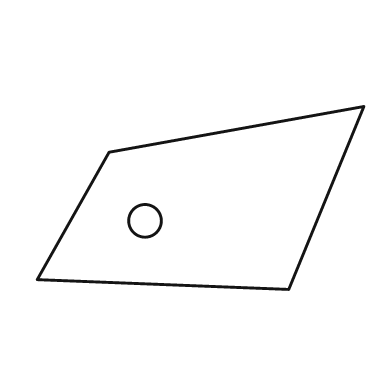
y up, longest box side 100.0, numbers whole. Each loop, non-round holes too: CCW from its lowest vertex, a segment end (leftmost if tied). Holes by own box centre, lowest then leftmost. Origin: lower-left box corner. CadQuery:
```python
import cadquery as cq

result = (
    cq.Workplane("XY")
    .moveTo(77.0, 0.0)
    .lineTo(100.0, 56.0)
    .lineTo(22.0, 42.0)
    .lineTo(0.0, 3.0)
    .close()
    .moveTo(33.0, 21.0)
    .circle(5.0)
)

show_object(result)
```